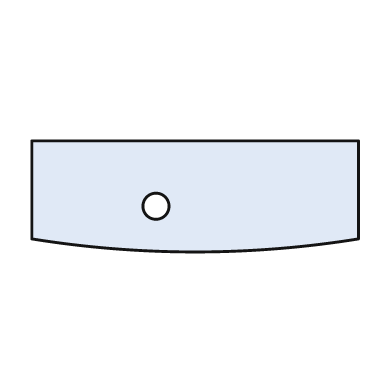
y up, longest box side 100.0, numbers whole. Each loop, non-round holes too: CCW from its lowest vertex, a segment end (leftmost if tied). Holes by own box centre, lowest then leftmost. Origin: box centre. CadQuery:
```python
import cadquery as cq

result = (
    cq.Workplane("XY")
    .moveTo(-50.0, -13.0)
    .threePointArc((0.0, -17.0), (50.0, -13.0))
    .lineTo(50.0, 17.0)
    .lineTo(-50.0, 17.0)
    .close()
    .moveTo(-12.0, -3.0)
    .circle(4.0)
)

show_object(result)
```